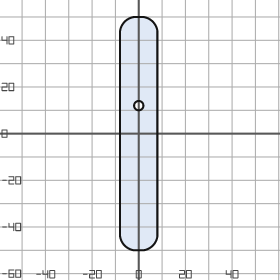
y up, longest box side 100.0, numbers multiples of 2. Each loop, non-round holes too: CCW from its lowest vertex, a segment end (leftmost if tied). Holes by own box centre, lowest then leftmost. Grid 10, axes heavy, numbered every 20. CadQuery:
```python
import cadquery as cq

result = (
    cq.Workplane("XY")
    .moveTo(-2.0, -50.0)
    .lineTo(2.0, -50.0)
    .threePointArc((6.0, -48.0), (8.0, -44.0))
    .lineTo(8.0, 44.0)
    .threePointArc((6.0, 48.0), (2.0, 50.0))
    .lineTo(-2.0, 50.0)
    .threePointArc((-6.0, 48.0), (-8.0, 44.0))
    .lineTo(-8.0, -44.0)
    .threePointArc((-6.0, -48.0), (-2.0, -50.0))
    .close()
    .moveTo(0.0, 12.0)
    .circle(2.0)
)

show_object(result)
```